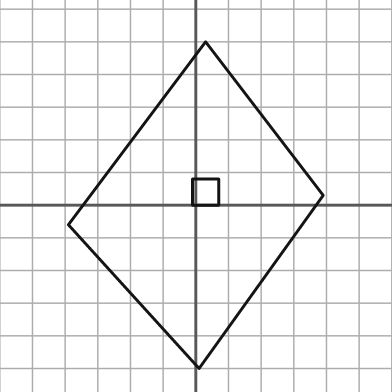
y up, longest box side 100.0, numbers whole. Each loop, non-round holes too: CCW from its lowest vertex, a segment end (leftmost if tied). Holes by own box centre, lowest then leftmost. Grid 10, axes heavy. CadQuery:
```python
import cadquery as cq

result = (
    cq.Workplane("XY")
    .moveTo(1.0, -50.0)
    .lineTo(39.0, 3.0)
    .lineTo(3.0, 50.0)
    .lineTo(-39.0, -6.0)
    .close()
    .moveTo(-1.0, 0.0)
    .lineTo(7.0, 0.0)
    .lineTo(7.0, 8.0)
    .lineTo(-1.0, 8.0)
    .close()
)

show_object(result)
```